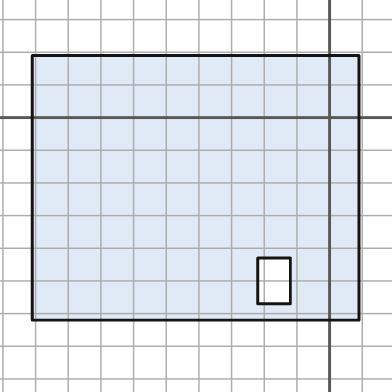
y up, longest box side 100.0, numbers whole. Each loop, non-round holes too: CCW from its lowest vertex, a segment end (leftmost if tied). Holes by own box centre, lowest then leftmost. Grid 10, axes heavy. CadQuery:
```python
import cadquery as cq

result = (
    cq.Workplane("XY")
    .moveTo(-91.0, -62.0)
    .lineTo(9.0, -62.0)
    .lineTo(9.0, 19.0)
    .lineTo(-91.0, 19.0)
    .close()
    .moveTo(-22.0, -57.0)
    .lineTo(-12.0, -57.0)
    .lineTo(-12.0, -43.0)
    .lineTo(-22.0, -43.0)
    .close()
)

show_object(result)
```